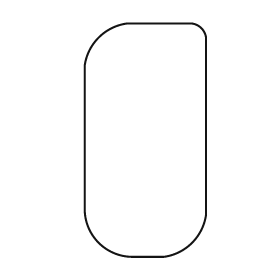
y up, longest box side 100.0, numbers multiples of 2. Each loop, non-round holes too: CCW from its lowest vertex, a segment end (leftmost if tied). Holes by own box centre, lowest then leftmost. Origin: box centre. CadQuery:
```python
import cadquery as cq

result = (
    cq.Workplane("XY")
    .moveTo(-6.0, -50.0)
    .lineTo(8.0, -50.0)
    .threePointArc((20.0, -44.0), (26.0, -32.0))
    .lineTo(26.0, 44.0)
    .threePointArc((24.0, 48.0), (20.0, 50.0))
    .lineTo(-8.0, 50.0)
    .threePointArc((-20.0, 44.0), (-26.0, 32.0))
    .lineTo(-26.0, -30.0)
    .threePointArc((-20.0, -44.0), (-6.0, -50.0))
    .close()
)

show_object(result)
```